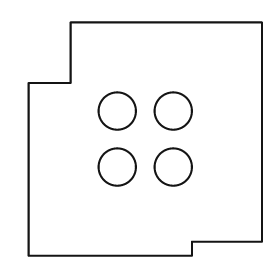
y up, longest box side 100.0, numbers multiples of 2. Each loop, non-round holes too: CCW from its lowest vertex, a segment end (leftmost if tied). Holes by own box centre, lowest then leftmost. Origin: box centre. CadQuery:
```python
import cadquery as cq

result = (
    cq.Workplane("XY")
    .moveTo(-50.0, -50.0)
    .lineTo(20.0, -50.0)
    .lineTo(20.0, -44.0)
    .lineTo(50.0, -44.0)
    .lineTo(50.0, 50.0)
    .lineTo(-32.0, 50.0)
    .lineTo(-32.0, 24.0)
    .lineTo(-50.0, 24.0)
    .close()
    .moveTo(-12.0, -12.0)
    .circle(8.0)
    .moveTo(12.0, -12.0)
    .circle(8.0)
    .moveTo(-12.0, 12.0)
    .circle(8.0)
    .moveTo(12.0, 12.0)
    .circle(8.0)
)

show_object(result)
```